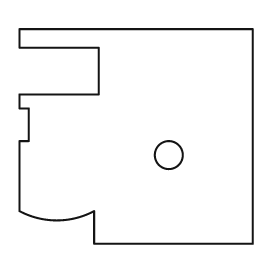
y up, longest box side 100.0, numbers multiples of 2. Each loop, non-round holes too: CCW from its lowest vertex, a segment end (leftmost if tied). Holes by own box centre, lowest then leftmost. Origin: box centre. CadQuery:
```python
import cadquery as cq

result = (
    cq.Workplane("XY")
    .moveTo(-18.0, -46.0)
    .lineTo(50.0, -46.0)
    .lineTo(50.0, 46.0)
    .lineTo(-50.0, 46.0)
    .lineTo(-50.0, 38.0)
    .lineTo(-16.0, 38.0)
    .lineTo(-16.0, 18.0)
    .lineTo(-50.0, 18.0)
    .lineTo(-50.0, 12.0)
    .lineTo(-46.0, 12.0)
    .lineTo(-46.0, -2.0)
    .lineTo(-50.0, -2.0)
    .lineTo(-50.0, -32.0)
    .threePointArc((-34.0, -36.0), (-18.0, -32.0))
    .close()
    .moveTo(14.0, -8.0)
    .circle(6.0)
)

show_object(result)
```